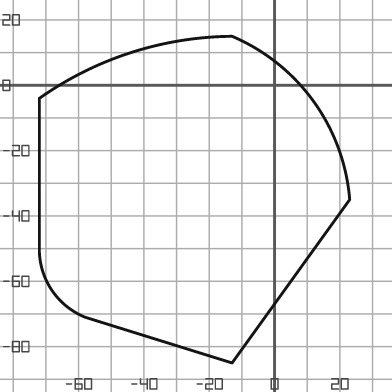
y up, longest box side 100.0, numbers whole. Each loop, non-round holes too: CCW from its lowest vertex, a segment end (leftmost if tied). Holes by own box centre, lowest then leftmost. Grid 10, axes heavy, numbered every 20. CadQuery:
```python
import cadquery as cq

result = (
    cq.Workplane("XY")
    .moveTo(-13.0, -85.0)
    .lineTo(23.0, -35.0)
    .threePointArc((12.0, -5.0), (-13.0, 15.0))
    .threePointArc((-44.0, 10.0), (-72.0, -4.0))
    .lineTo(-72.0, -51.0)
    .threePointArc((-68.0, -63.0), (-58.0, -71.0))
    .close()
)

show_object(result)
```